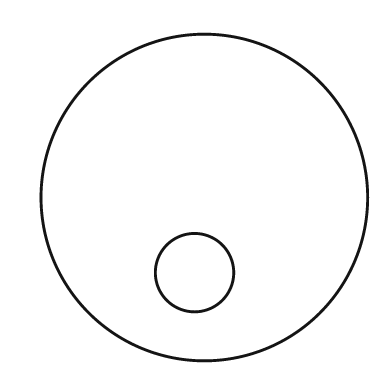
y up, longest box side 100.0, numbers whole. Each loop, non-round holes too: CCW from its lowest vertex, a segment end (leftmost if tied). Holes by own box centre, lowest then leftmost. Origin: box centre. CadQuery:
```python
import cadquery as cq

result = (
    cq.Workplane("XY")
    .moveTo(0.0, 0.0)
    .circle(50.0)
    .moveTo(-3.0, -23.0)
    .circle(12.0)
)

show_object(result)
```